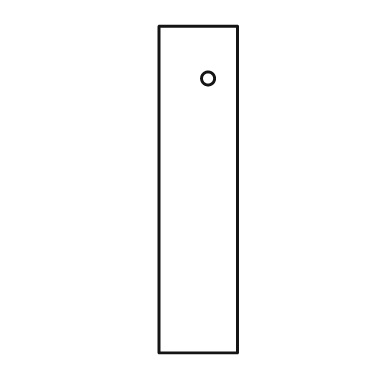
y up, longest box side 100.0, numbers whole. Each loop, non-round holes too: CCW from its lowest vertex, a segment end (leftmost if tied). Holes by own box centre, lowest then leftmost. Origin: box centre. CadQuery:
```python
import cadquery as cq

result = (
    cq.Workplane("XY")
    .moveTo(-12.0, -50.0)
    .lineTo(12.0, -50.0)
    .lineTo(12.0, 50.0)
    .lineTo(-12.0, 50.0)
    .close()
    .moveTo(3.0, 34.0)
    .circle(2.0)
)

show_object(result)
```